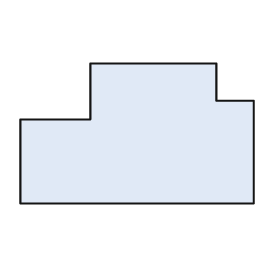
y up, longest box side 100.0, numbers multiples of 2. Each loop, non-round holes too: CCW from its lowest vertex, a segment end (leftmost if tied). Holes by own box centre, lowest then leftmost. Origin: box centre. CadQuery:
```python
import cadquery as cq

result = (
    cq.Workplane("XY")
    .moveTo(-50.0, -30.0)
    .lineTo(50.0, -30.0)
    .lineTo(50.0, 14.0)
    .lineTo(34.0, 14.0)
    .lineTo(34.0, 30.0)
    .lineTo(-20.0, 30.0)
    .lineTo(-20.0, 6.0)
    .lineTo(-50.0, 6.0)
    .close()
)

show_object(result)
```